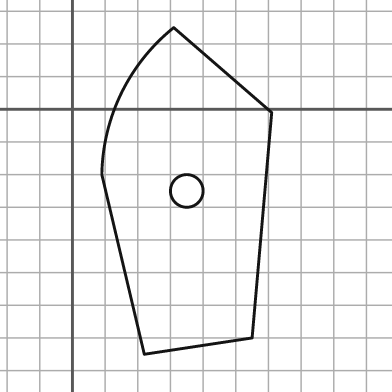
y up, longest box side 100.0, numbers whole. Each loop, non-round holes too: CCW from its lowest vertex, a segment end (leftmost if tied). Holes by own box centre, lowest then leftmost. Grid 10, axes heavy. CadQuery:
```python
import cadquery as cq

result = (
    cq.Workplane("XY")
    .moveTo(22.0, -75.0)
    .lineTo(55.0, -70.0)
    .lineTo(61.0, -1.0)
    .lineTo(31.0, 25.0)
    .threePointArc((15.0, 5.0), (9.0, -20.0))
    .close()
    .moveTo(35.0, -25.0)
    .circle(5.0)
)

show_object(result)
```